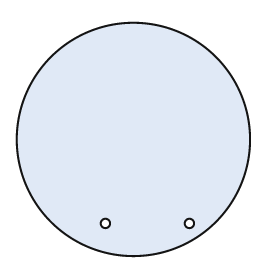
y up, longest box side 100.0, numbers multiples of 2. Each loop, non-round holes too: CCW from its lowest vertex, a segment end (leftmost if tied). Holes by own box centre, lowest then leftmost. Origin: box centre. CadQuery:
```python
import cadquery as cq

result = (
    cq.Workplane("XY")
    .moveTo(0.0, 0.0)
    .circle(50.0)
    .moveTo(-12.0, -36.0)
    .circle(2.0)
    .moveTo(24.0, -36.0)
    .circle(2.0)
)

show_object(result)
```